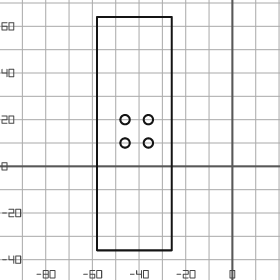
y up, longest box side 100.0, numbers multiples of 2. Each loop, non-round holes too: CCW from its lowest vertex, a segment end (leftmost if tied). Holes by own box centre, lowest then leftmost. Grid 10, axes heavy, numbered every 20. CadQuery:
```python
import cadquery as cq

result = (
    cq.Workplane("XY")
    .moveTo(-58.0, -36.0)
    .lineTo(-26.0, -36.0)
    .lineTo(-26.0, 64.0)
    .lineTo(-58.0, 64.0)
    .close()
    .moveTo(-46.0, 10.0)
    .circle(2.0)
    .moveTo(-36.0, 10.0)
    .circle(2.0)
    .moveTo(-46.0, 20.0)
    .circle(2.0)
    .moveTo(-36.0, 20.0)
    .circle(2.0)
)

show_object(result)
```